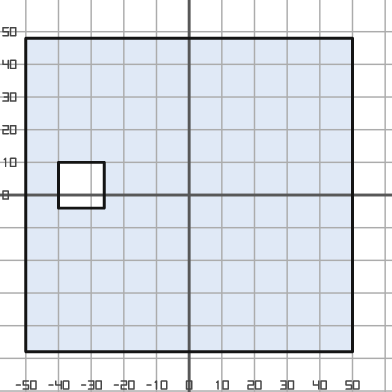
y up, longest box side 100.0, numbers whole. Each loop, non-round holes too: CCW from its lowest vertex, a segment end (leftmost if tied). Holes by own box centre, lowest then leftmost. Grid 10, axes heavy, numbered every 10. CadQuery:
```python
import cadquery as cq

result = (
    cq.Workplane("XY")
    .moveTo(-50.0, -48.0)
    .lineTo(50.0, -48.0)
    .lineTo(50.0, 48.0)
    .lineTo(-50.0, 48.0)
    .close()
    .moveTo(-40.0, -4.0)
    .lineTo(-26.0, -4.0)
    .lineTo(-26.0, 10.0)
    .lineTo(-40.0, 10.0)
    .close()
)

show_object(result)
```